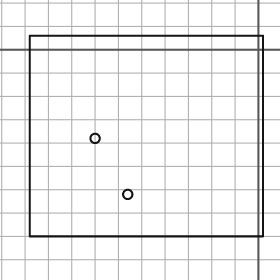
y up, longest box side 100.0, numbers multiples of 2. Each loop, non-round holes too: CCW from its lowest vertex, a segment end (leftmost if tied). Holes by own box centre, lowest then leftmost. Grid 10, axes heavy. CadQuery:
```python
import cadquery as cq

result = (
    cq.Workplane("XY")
    .moveTo(-98.0, -80.0)
    .lineTo(2.0, -80.0)
    .lineTo(2.0, 6.0)
    .lineTo(-98.0, 6.0)
    .close()
    .moveTo(-56.0, -62.0)
    .circle(2.0)
    .moveTo(-70.0, -38.0)
    .circle(2.0)
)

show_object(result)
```